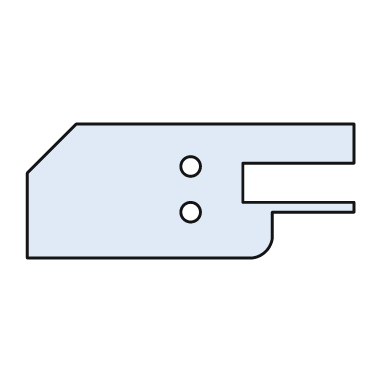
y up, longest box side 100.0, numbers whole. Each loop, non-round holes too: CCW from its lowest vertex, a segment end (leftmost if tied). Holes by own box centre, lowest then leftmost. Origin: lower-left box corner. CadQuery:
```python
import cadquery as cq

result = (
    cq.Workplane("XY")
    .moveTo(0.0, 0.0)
    .lineTo(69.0, 0.0)
    .threePointArc((73.0, 2.0), (75.0, 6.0))
    .lineTo(75.0, 14.0)
    .lineTo(100.0, 14.0)
    .lineTo(100.0, 17.0)
    .lineTo(66.0, 17.0)
    .lineTo(66.0, 29.0)
    .lineTo(100.0, 29.0)
    .lineTo(100.0, 41.0)
    .lineTo(15.0, 41.0)
    .lineTo(0.0, 26.0)
    .close()
    .moveTo(50.0, 14.0)
    .circle(3.0)
    .moveTo(50.0, 28.0)
    .circle(3.0)
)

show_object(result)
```